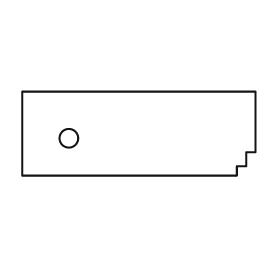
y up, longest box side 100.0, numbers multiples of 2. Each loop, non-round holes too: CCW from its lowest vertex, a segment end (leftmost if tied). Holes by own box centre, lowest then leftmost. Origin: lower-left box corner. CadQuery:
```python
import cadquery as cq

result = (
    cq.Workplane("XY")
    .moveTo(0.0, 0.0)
    .lineTo(92.0, 0.0)
    .lineTo(92.0, 4.0)
    .lineTo(96.0, 4.0)
    .lineTo(96.0, 10.0)
    .lineTo(100.0, 10.0)
    .lineTo(100.0, 36.0)
    .lineTo(0.0, 36.0)
    .close()
    .moveTo(20.0, 16.0)
    .circle(4.0)
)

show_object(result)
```